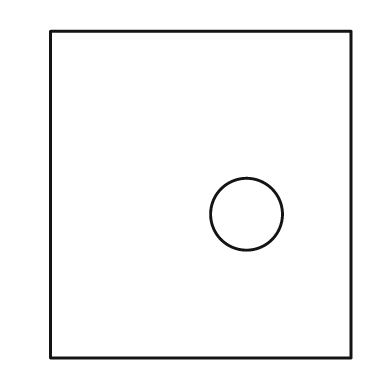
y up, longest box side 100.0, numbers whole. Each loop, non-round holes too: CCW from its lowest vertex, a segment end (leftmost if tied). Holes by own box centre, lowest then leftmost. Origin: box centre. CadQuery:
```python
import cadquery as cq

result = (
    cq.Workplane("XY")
    .moveTo(-46.0, -50.0)
    .lineTo(46.0, -50.0)
    .lineTo(46.0, 50.0)
    .lineTo(-46.0, 50.0)
    .close()
    .moveTo(14.0, -6.0)
    .circle(11.0)
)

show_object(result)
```